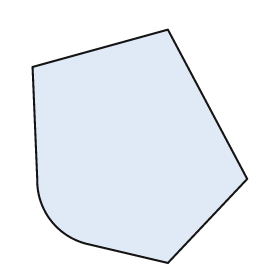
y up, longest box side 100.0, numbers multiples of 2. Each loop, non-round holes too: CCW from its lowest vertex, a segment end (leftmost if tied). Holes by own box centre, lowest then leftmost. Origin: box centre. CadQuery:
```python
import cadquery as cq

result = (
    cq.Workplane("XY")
    .moveTo(12.0, -50.0)
    .lineTo(46.0, -14.0)
    .lineTo(12.0, 50.0)
    .lineTo(-46.0, 34.0)
    .lineTo(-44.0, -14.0)
    .threePointArc((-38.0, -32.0), (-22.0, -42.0))
    .close()
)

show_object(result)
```